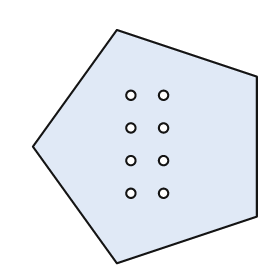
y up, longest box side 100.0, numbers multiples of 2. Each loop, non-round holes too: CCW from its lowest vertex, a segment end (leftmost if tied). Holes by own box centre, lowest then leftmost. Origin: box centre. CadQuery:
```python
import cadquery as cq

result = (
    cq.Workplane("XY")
    .moveTo(-12.0, -50.0)
    .lineTo(48.0, -30.0)
    .lineTo(48.0, 30.0)
    .lineTo(-12.0, 50.0)
    .lineTo(-48.0, 0.0)
    .close()
    .moveTo(-6.0, -20.0)
    .circle(2.0)
    .moveTo(8.0, -20.0)
    .circle(2.0)
    .moveTo(-6.0, -6.0)
    .circle(2.0)
    .moveTo(8.0, -6.0)
    .circle(2.0)
    .moveTo(-6.0, 8.0)
    .circle(2.0)
    .moveTo(8.0, 8.0)
    .circle(2.0)
    .moveTo(-6.0, 22.0)
    .circle(2.0)
    .moveTo(8.0, 22.0)
    .circle(2.0)
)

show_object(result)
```